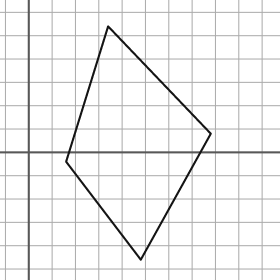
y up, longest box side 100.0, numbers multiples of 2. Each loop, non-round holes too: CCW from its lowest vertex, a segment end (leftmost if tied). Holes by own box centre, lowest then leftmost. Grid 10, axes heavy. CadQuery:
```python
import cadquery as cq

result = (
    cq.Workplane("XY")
    .moveTo(48.0, -46.0)
    .lineTo(78.0, 8.0)
    .lineTo(34.0, 54.0)
    .lineTo(16.0, -4.0)
    .close()
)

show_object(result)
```